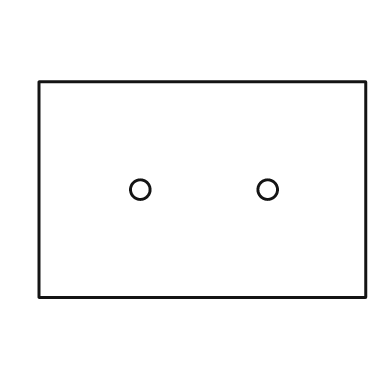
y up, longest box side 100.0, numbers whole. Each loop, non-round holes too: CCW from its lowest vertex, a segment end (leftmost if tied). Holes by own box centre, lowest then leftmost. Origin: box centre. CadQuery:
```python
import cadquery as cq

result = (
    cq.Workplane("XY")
    .moveTo(-50.0, -33.0)
    .lineTo(50.0, -33.0)
    .lineTo(50.0, 33.0)
    .lineTo(-50.0, 33.0)
    .close()
    .moveTo(-19.0, 0.0)
    .circle(3.0)
    .moveTo(20.0, 0.0)
    .circle(3.0)
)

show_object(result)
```